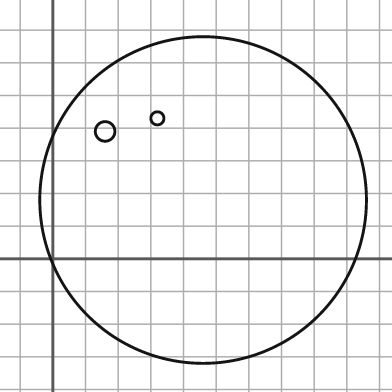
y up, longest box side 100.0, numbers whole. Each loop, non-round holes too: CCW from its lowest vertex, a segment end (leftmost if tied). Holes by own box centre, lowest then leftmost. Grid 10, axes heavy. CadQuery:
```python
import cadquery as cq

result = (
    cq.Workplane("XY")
    .moveTo(46.0, 18.0)
    .circle(50.0)
    .moveTo(16.0, 39.0)
    .circle(3.0)
    .moveTo(32.0, 43.0)
    .circle(2.0)
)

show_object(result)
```